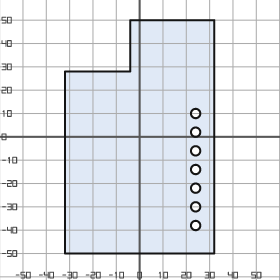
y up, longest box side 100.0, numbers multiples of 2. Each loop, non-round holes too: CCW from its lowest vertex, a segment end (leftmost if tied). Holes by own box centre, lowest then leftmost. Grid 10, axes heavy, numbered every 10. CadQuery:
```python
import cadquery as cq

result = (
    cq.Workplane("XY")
    .moveTo(-32.0, -50.0)
    .lineTo(32.0, -50.0)
    .lineTo(32.0, 50.0)
    .lineTo(-4.0, 50.0)
    .lineTo(-4.0, 28.0)
    .lineTo(-32.0, 28.0)
    .close()
    .moveTo(24.0, -38.0)
    .circle(2.0)
    .moveTo(24.0, -30.0)
    .circle(2.0)
    .moveTo(24.0, -22.0)
    .circle(2.0)
    .moveTo(24.0, -14.0)
    .circle(2.0)
    .moveTo(24.0, -6.0)
    .circle(2.0)
    .moveTo(24.0, 2.0)
    .circle(2.0)
    .moveTo(24.0, 10.0)
    .circle(2.0)
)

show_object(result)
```